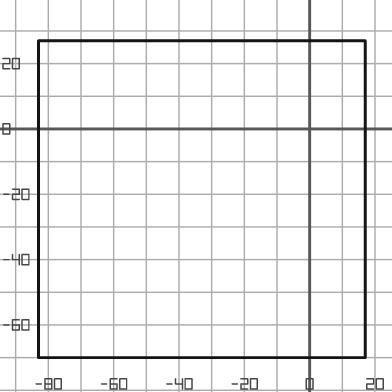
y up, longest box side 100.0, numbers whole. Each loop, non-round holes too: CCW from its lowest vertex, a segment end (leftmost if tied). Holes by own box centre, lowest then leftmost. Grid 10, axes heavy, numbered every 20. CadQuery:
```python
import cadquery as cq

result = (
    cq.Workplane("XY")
    .moveTo(-83.0, -70.0)
    .lineTo(17.0, -70.0)
    .lineTo(17.0, 27.0)
    .lineTo(-83.0, 27.0)
    .close()
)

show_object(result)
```